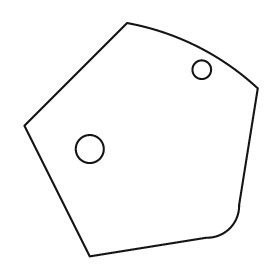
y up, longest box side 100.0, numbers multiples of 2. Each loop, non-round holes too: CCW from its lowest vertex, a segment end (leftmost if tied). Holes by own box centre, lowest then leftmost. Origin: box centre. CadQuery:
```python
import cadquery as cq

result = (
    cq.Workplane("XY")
    .moveTo(-22.0, -50.0)
    .lineTo(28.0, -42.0)
    .threePointArc((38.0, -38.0), (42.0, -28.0))
    .lineTo(50.0, 22.0)
    .threePointArc((24.0, 40.0), (-6.0, 50.0))
    .lineTo(-50.0, 6.0)
    .close()
    .moveTo(-22.0, -4.0)
    .circle(6.0)
    .moveTo(26.0, 30.0)
    .circle(4.0)
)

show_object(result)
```